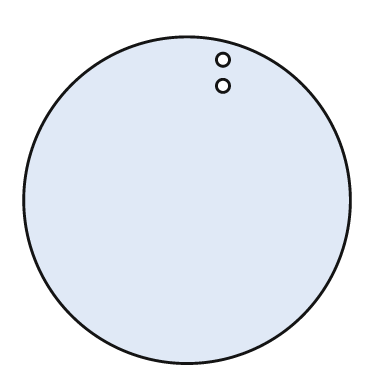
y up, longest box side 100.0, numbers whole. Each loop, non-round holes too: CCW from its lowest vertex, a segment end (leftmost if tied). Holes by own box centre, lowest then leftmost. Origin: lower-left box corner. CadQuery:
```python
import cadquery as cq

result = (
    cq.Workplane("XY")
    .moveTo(50.0, 50.0)
    .circle(50.0)
    .moveTo(61.0, 85.0)
    .circle(2.0)
    .moveTo(61.0, 93.0)
    .circle(2.0)
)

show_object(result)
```